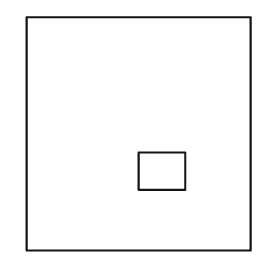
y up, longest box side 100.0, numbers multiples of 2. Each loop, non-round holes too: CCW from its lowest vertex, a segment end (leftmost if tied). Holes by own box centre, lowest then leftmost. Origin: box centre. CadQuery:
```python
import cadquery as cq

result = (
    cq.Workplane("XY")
    .moveTo(-48.0, -50.0)
    .lineTo(48.0, -50.0)
    .lineTo(48.0, 50.0)
    .lineTo(-48.0, 50.0)
    .close()
    .moveTo(0.0, -24.0)
    .lineTo(20.0, -24.0)
    .lineTo(20.0, -8.0)
    .lineTo(0.0, -8.0)
    .close()
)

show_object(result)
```